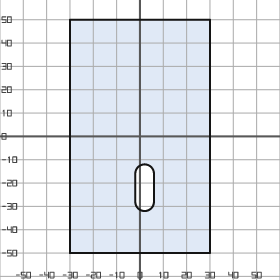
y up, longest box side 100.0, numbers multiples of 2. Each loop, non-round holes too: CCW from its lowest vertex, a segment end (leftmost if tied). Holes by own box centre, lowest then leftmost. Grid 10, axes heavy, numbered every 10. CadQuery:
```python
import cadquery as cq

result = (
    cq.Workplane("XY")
    .moveTo(-30.0, -50.0)
    .lineTo(30.0, -50.0)
    .lineTo(30.0, 50.0)
    .lineTo(-30.0, 50.0)
    .close()
    .moveTo(-2.0, -28.0)
    .threePointArc((2.0, -32.0), (6.0, -28.0))
    .lineTo(6.0, -16.0)
    .threePointArc((2.0, -12.0), (-2.0, -16.0))
    .close()
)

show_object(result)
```